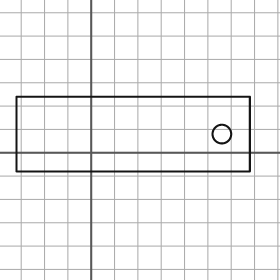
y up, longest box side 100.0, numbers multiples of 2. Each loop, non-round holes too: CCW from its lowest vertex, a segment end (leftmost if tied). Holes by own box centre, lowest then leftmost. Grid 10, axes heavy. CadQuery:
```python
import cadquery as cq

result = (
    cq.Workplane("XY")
    .moveTo(-32.0, -8.0)
    .lineTo(68.0, -8.0)
    .lineTo(68.0, 24.0)
    .lineTo(-32.0, 24.0)
    .close()
    .moveTo(56.0, 8.0)
    .circle(4.0)
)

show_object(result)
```